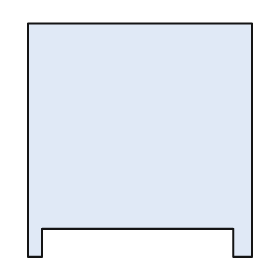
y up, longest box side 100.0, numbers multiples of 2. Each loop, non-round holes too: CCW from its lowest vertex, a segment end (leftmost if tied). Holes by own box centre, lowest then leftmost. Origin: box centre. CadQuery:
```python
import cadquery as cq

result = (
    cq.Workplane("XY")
    .moveTo(-48.0, -50.0)
    .lineTo(-42.0, -50.0)
    .lineTo(-42.0, -38.0)
    .lineTo(40.0, -38.0)
    .lineTo(40.0, -50.0)
    .lineTo(48.0, -50.0)
    .lineTo(48.0, 50.0)
    .lineTo(-48.0, 50.0)
    .close()
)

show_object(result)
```